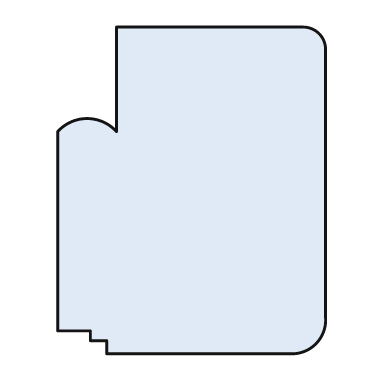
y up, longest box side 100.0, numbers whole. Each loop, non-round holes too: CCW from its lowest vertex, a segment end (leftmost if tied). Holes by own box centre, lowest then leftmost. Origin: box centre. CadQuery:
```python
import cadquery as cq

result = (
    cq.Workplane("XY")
    .moveTo(-26.0, -50.0)
    .lineTo(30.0, -50.0)
    .threePointArc((38.0, -47.0), (41.0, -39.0))
    .lineTo(41.0, 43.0)
    .threePointArc((39.0, 48.0), (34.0, 50.0))
    .lineTo(-23.0, 50.0)
    .lineTo(-23.0, 18.0)
    .threePointArc((-32.0, 22.0), (-41.0, 18.0))
    .lineTo(-41.0, -43.0)
    .lineTo(-31.0, -43.0)
    .lineTo(-31.0, -46.0)
    .lineTo(-26.0, -46.0)
    .close()
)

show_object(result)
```